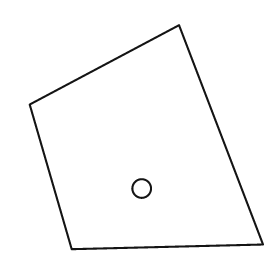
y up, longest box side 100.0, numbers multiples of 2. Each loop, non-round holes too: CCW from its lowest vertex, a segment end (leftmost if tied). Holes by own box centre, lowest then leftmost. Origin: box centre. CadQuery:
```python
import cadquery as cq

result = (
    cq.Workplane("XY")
    .moveTo(-32.0, -48.0)
    .lineTo(50.0, -46.0)
    .lineTo(14.0, 48.0)
    .lineTo(-50.0, 14.0)
    .close()
    .moveTo(-2.0, -22.0)
    .circle(4.0)
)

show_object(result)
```